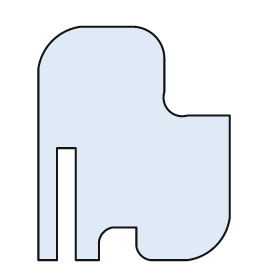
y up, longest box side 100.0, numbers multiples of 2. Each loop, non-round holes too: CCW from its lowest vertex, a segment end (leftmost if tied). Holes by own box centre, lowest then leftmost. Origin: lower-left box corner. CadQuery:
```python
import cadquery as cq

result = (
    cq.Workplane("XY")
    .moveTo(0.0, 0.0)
    .lineTo(8.0, 0.0)
    .lineTo(8.0, 48.0)
    .lineTo(16.0, 48.0)
    .lineTo(16.0, 0.0)
    .lineTo(26.0, 0.0)
    .lineTo(26.0, 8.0)
    .threePointArc((28.0, 12.0), (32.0, 14.0))
    .lineTo(42.0, 14.0)
    .lineTo(42.0, 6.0)
    .threePointArc((44.0, 2.0), (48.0, 0.0))
    .lineTo(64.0, 0.0)
    .threePointArc((76.0, 6.0), (82.0, 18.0))
    .lineTo(82.0, 62.0)
    .lineTo(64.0, 62.0)
    .threePointArc((56.0, 64.0), (54.0, 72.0))
    .lineTo(54.0, 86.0)
    .threePointArc((50.0, 96.0), (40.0, 100.0))
    .lineTo(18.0, 100.0)
    .threePointArc((6.0, 94.0), (0.0, 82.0))
    .close()
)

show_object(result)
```